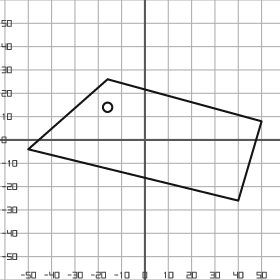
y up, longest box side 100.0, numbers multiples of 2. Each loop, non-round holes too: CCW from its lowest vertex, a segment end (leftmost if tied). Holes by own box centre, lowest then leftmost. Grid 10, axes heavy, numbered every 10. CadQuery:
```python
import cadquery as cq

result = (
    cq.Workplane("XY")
    .moveTo(40.0, -26.0)
    .lineTo(50.0, 8.0)
    .lineTo(-16.0, 26.0)
    .lineTo(-50.0, -4.0)
    .close()
    .moveTo(-16.0, 14.0)
    .circle(2.0)
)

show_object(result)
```